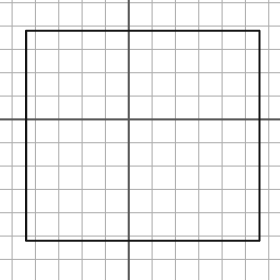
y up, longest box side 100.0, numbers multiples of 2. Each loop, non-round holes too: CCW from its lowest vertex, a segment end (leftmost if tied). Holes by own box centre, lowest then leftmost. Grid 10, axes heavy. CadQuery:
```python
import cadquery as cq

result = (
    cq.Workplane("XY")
    .moveTo(-44.0, -52.0)
    .lineTo(56.0, -52.0)
    .lineTo(56.0, 38.0)
    .lineTo(-44.0, 38.0)
    .close()
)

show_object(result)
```